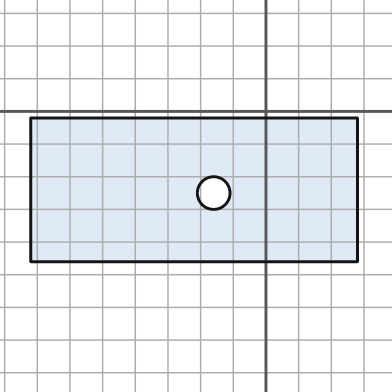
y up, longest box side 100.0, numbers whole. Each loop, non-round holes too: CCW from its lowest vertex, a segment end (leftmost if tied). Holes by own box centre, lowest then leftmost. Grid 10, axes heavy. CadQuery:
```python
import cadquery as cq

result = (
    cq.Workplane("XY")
    .moveTo(-72.0, -46.0)
    .lineTo(28.0, -46.0)
    .lineTo(28.0, -2.0)
    .lineTo(-72.0, -2.0)
    .close()
    .moveTo(-16.0, -25.0)
    .circle(5.0)
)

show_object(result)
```